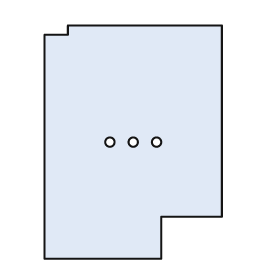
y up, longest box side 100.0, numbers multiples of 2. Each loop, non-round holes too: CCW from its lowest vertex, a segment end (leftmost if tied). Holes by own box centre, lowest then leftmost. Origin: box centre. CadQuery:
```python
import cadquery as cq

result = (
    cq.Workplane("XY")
    .moveTo(-38.0, -50.0)
    .lineTo(12.0, -50.0)
    .lineTo(12.0, -32.0)
    .lineTo(38.0, -32.0)
    .lineTo(38.0, 50.0)
    .lineTo(-28.0, 50.0)
    .lineTo(-28.0, 46.0)
    .lineTo(-38.0, 46.0)
    .close()
    .moveTo(-10.0, 0.0)
    .circle(2.0)
    .moveTo(0.0, 0.0)
    .circle(2.0)
    .moveTo(10.0, 0.0)
    .circle(2.0)
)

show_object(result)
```